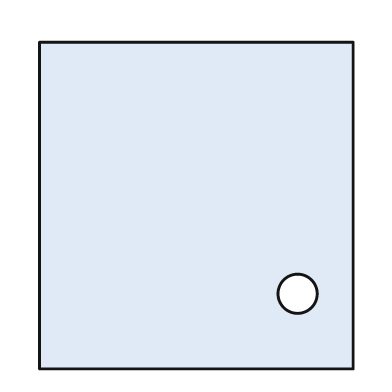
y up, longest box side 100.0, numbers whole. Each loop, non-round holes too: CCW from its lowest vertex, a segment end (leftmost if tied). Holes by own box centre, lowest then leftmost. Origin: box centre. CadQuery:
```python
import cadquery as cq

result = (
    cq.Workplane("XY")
    .moveTo(-48.0, -50.0)
    .lineTo(48.0, -50.0)
    .lineTo(48.0, 50.0)
    .lineTo(-48.0, 50.0)
    .close()
    .moveTo(31.0, -27.0)
    .circle(6.0)
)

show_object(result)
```